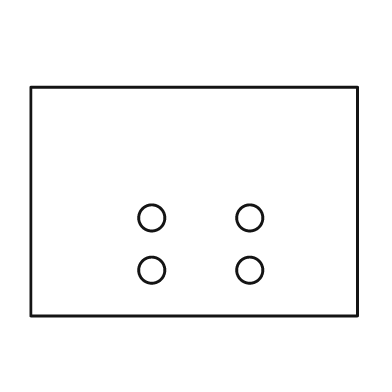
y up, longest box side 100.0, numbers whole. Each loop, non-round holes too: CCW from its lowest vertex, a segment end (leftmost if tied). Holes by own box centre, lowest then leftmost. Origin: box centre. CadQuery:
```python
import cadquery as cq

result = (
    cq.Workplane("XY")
    .moveTo(-50.0, -35.0)
    .lineTo(50.0, -35.0)
    .lineTo(50.0, 35.0)
    .lineTo(-50.0, 35.0)
    .close()
    .moveTo(-13.0, -21.0)
    .circle(4.0)
    .moveTo(17.0, -21.0)
    .circle(4.0)
    .moveTo(-13.0, -5.0)
    .circle(4.0)
    .moveTo(17.0, -5.0)
    .circle(4.0)
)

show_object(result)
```